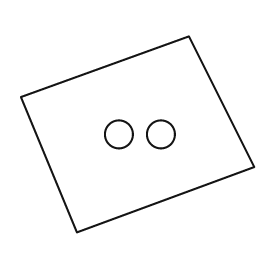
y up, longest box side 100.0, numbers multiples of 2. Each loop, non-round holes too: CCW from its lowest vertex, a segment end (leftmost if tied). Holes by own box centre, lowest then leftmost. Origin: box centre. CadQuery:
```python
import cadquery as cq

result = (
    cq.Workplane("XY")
    .moveTo(-26.0, -42.0)
    .lineTo(50.0, -14.0)
    .lineTo(22.0, 42.0)
    .lineTo(-50.0, 16.0)
    .close()
    .moveTo(-8.0, 0.0)
    .circle(6.0)
    .moveTo(10.0, 0.0)
    .circle(6.0)
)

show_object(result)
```